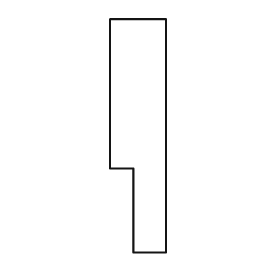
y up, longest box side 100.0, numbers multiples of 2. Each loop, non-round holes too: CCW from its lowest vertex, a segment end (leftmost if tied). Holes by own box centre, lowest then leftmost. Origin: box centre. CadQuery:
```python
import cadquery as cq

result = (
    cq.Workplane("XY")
    .moveTo(-2.0, -50.0)
    .lineTo(12.0, -50.0)
    .lineTo(12.0, 50.0)
    .lineTo(-12.0, 50.0)
    .lineTo(-12.0, -14.0)
    .lineTo(-2.0, -14.0)
    .close()
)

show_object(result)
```